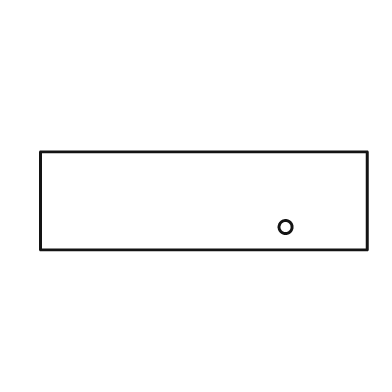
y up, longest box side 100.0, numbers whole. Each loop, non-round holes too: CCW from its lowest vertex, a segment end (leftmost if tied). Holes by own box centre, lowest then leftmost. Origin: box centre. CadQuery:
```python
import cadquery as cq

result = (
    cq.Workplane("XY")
    .moveTo(-50.0, -15.0)
    .lineTo(50.0, -15.0)
    .lineTo(50.0, 15.0)
    .lineTo(-50.0, 15.0)
    .close()
    .moveTo(25.0, -8.0)
    .circle(2.0)
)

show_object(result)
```